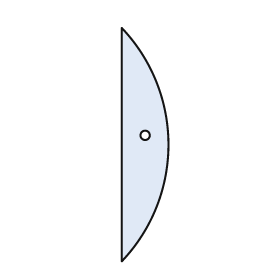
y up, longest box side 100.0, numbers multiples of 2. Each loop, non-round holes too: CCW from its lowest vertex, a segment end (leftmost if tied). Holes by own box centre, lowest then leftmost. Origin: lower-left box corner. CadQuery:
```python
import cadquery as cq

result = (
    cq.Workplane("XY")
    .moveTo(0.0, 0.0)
    .threePointArc((20.0, 50.0), (0.0, 100.0))
    .close()
    .moveTo(10.0, 54.0)
    .circle(2.0)
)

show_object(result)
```